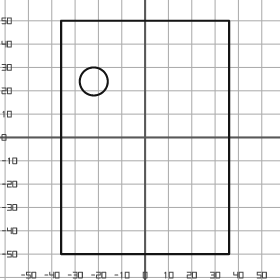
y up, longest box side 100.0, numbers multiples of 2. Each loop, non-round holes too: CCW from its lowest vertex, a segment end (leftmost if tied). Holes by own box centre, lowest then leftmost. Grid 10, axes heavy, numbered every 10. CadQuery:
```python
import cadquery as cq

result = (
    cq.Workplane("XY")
    .moveTo(-36.0, -50.0)
    .lineTo(36.0, -50.0)
    .lineTo(36.0, 50.0)
    .lineTo(-36.0, 50.0)
    .close()
    .moveTo(-22.0, 24.0)
    .circle(6.0)
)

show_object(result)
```